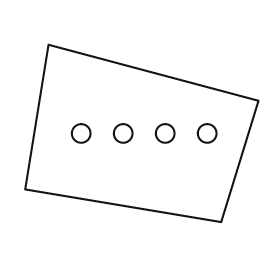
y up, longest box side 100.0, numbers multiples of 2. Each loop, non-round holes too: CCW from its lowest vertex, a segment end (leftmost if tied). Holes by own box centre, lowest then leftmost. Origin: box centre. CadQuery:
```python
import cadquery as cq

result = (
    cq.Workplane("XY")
    .moveTo(34.0, -38.0)
    .lineTo(50.0, 14.0)
    .lineTo(-40.0, 38.0)
    .lineTo(-50.0, -24.0)
    .close()
    .moveTo(-26.0, 0.0)
    .circle(4.0)
    .moveTo(-8.0, 0.0)
    .circle(4.0)
    .moveTo(10.0, 0.0)
    .circle(4.0)
    .moveTo(28.0, 0.0)
    .circle(4.0)
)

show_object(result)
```